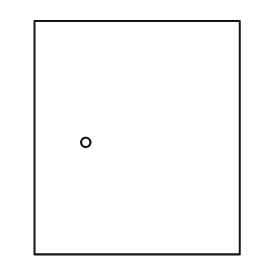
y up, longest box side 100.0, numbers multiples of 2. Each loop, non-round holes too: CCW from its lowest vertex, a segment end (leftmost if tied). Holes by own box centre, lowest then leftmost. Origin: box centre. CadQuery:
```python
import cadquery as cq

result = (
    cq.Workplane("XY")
    .moveTo(-44.0, -50.0)
    .lineTo(44.0, -50.0)
    .lineTo(44.0, 50.0)
    .lineTo(-44.0, 50.0)
    .close()
    .moveTo(-22.0, -2.0)
    .circle(2.0)
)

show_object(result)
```